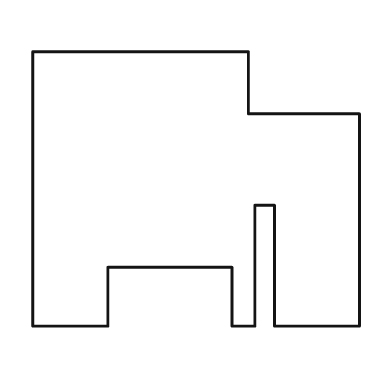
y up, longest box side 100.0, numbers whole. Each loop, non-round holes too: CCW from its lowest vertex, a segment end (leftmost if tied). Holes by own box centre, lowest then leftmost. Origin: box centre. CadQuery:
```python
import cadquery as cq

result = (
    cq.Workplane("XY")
    .moveTo(-50.0, -42.0)
    .lineTo(-27.0, -42.0)
    .lineTo(-27.0, -24.0)
    .lineTo(11.0, -24.0)
    .lineTo(11.0, -42.0)
    .lineTo(18.0, -42.0)
    .lineTo(18.0, -5.0)
    .lineTo(24.0, -5.0)
    .lineTo(24.0, -42.0)
    .lineTo(50.0, -42.0)
    .lineTo(50.0, 23.0)
    .lineTo(16.0, 23.0)
    .lineTo(16.0, 42.0)
    .lineTo(-50.0, 42.0)
    .close()
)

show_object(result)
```